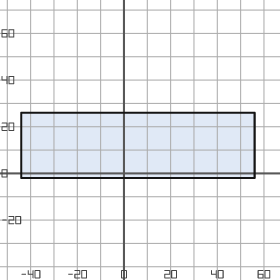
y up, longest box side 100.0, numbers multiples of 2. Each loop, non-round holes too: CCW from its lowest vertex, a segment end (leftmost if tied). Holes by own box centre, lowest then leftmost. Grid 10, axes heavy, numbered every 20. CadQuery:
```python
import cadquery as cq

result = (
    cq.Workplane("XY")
    .moveTo(-44.0, -2.0)
    .lineTo(56.0, -2.0)
    .lineTo(56.0, 26.0)
    .lineTo(-44.0, 26.0)
    .close()
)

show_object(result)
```